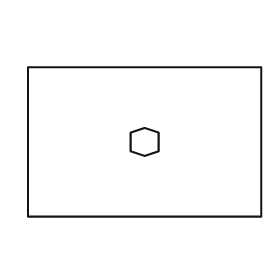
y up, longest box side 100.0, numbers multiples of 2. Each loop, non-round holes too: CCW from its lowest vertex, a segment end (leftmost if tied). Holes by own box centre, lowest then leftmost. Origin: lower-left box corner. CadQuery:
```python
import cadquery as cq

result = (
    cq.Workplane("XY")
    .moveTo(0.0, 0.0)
    .lineTo(100.0, 0.0)
    .lineTo(100.0, 64.0)
    .lineTo(0.0, 64.0)
    .close()
    .moveTo(50.0, 26.0)
    .lineTo(56.0, 28.0)
    .lineTo(56.0, 36.0)
    .lineTo(50.0, 38.0)
    .lineTo(44.0, 36.0)
    .lineTo(44.0, 28.0)
    .close()
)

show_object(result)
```